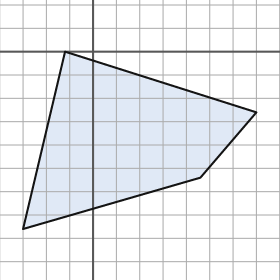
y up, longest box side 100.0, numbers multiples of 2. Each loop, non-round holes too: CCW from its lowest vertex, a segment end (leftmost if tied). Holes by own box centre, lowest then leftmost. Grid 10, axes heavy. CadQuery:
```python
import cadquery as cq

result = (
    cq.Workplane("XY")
    .moveTo(-30.0, -76.0)
    .lineTo(46.0, -54.0)
    .lineTo(70.0, -26.0)
    .lineTo(-12.0, 0.0)
    .close()
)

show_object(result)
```